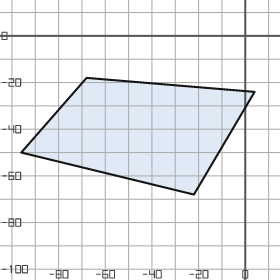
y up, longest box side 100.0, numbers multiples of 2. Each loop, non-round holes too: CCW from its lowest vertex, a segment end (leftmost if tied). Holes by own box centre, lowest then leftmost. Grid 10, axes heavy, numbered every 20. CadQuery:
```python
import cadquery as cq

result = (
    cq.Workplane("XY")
    .moveTo(-22.0, -68.0)
    .lineTo(4.0, -24.0)
    .lineTo(-68.0, -18.0)
    .lineTo(-96.0, -50.0)
    .close()
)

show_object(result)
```